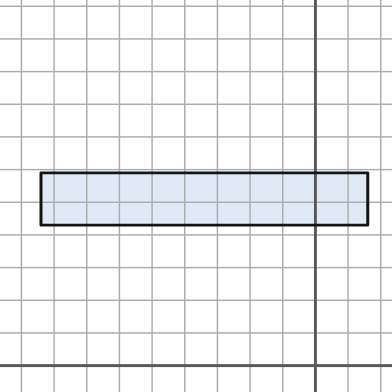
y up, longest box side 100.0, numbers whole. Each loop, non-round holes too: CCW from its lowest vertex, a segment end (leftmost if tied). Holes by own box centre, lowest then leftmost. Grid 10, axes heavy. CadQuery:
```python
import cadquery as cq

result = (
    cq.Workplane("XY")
    .moveTo(-84.0, 43.0)
    .lineTo(16.0, 43.0)
    .lineTo(16.0, 59.0)
    .lineTo(-84.0, 59.0)
    .close()
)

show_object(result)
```